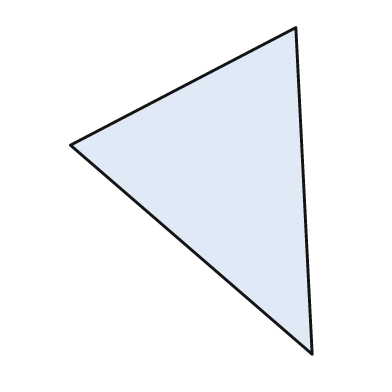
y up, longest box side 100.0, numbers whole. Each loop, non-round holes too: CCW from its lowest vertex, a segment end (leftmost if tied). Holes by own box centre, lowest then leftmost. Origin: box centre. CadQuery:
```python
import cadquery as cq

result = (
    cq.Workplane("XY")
    .moveTo(37.0, -50.0)
    .lineTo(32.0, 50.0)
    .lineTo(-37.0, 14.0)
    .close()
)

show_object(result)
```